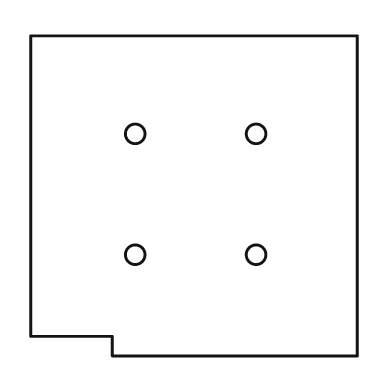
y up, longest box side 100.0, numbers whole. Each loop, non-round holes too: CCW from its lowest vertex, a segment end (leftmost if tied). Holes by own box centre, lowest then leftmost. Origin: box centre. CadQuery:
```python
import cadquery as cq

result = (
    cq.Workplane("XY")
    .moveTo(-25.0, -49.0)
    .lineTo(50.0, -49.0)
    .lineTo(50.0, 49.0)
    .lineTo(-50.0, 49.0)
    .lineTo(-50.0, -43.0)
    .lineTo(-25.0, -43.0)
    .close()
    .moveTo(-18.0, -18.0)
    .circle(3.0)
    .moveTo(19.0, -18.0)
    .circle(3.0)
    .moveTo(-18.0, 19.0)
    .circle(3.0)
    .moveTo(19.0, 19.0)
    .circle(3.0)
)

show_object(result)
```